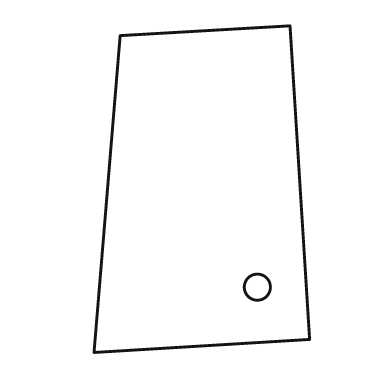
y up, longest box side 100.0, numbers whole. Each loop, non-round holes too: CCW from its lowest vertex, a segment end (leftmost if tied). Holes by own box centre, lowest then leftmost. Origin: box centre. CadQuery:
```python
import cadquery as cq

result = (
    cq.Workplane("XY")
    .moveTo(-33.0, -50.0)
    .lineTo(33.0, -46.0)
    .lineTo(27.0, 50.0)
    .lineTo(-25.0, 47.0)
    .close()
    .moveTo(17.0, -30.0)
    .circle(4.0)
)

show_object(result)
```